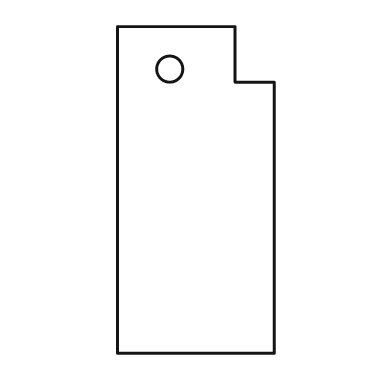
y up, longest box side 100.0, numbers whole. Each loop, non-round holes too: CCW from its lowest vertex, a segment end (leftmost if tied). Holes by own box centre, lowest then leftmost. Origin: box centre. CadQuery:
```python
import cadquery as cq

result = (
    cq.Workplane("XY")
    .moveTo(-24.0, -50.0)
    .lineTo(24.0, -50.0)
    .lineTo(24.0, 33.0)
    .lineTo(12.0, 33.0)
    .lineTo(12.0, 50.0)
    .lineTo(-24.0, 50.0)
    .close()
    .moveTo(-8.0, 37.0)
    .circle(4.0)
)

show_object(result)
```